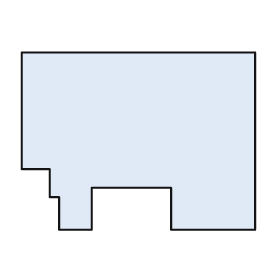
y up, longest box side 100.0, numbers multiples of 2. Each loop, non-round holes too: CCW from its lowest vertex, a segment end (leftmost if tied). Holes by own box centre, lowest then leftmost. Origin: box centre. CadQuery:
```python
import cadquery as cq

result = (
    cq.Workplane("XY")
    .moveTo(-34.0, -38.0)
    .lineTo(-20.0, -38.0)
    .lineTo(-20.0, -20.0)
    .lineTo(14.0, -20.0)
    .lineTo(14.0, -38.0)
    .lineTo(50.0, -38.0)
    .lineTo(50.0, 38.0)
    .lineTo(-50.0, 38.0)
    .lineTo(-50.0, -12.0)
    .lineTo(-38.0, -12.0)
    .lineTo(-38.0, -24.0)
    .lineTo(-34.0, -24.0)
    .close()
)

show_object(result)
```